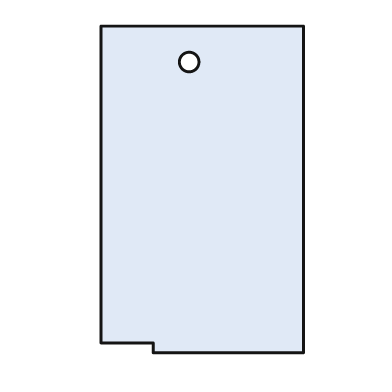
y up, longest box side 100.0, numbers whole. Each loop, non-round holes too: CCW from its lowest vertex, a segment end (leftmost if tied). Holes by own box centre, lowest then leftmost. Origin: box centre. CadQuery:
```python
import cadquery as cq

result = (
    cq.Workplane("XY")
    .moveTo(-15.0, -50.0)
    .lineTo(31.0, -50.0)
    .lineTo(31.0, 50.0)
    .lineTo(-31.0, 50.0)
    .lineTo(-31.0, -47.0)
    .lineTo(-15.0, -47.0)
    .close()
    .moveTo(-4.0, 39.0)
    .circle(3.0)
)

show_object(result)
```